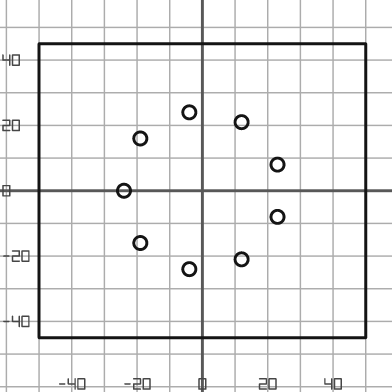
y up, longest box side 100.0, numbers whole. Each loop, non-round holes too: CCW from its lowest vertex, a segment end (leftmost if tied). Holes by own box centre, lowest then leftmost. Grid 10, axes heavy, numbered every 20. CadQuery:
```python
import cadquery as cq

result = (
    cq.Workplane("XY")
    .moveTo(-50.0, -45.0)
    .lineTo(50.0, -45.0)
    .lineTo(50.0, 45.0)
    .lineTo(-50.0, 45.0)
    .close()
    .moveTo(-4.0, -24.0)
    .circle(2.0)
    .moveTo(12.0, -21.0)
    .circle(2.0)
    .moveTo(-19.0, -16.0)
    .circle(2.0)
    .moveTo(23.0, -8.0)
    .circle(2.0)
    .moveTo(-24.0, 0.0)
    .circle(2.0)
    .moveTo(23.0, 8.0)
    .circle(2.0)
    .moveTo(-19.0, 16.0)
    .circle(2.0)
    .moveTo(12.0, 21.0)
    .circle(2.0)
    .moveTo(-4.0, 24.0)
    .circle(2.0)
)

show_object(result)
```